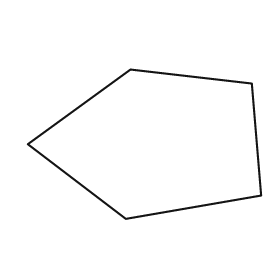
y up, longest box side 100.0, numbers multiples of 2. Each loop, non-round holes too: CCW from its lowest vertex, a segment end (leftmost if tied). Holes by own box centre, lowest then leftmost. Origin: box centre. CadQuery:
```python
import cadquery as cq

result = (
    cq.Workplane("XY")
    .moveTo(-8.0, -32.0)
    .lineTo(50.0, -22.0)
    .lineTo(46.0, 26.0)
    .lineTo(-6.0, 32.0)
    .lineTo(-50.0, 0.0)
    .close()
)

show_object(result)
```